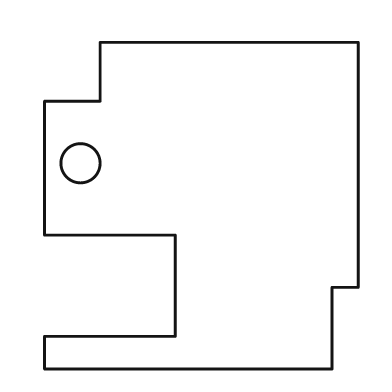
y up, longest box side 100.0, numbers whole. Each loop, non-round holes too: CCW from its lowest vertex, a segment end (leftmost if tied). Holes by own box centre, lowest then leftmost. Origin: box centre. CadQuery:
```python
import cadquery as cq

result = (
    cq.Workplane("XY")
    .moveTo(-48.0, -50.0)
    .lineTo(40.0, -50.0)
    .lineTo(40.0, -25.0)
    .lineTo(48.0, -25.0)
    .lineTo(48.0, 50.0)
    .lineTo(-31.0, 50.0)
    .lineTo(-31.0, 32.0)
    .lineTo(-48.0, 32.0)
    .lineTo(-48.0, -9.0)
    .lineTo(-8.0, -9.0)
    .lineTo(-8.0, -40.0)
    .lineTo(-48.0, -40.0)
    .close()
    .moveTo(-37.0, 13.0)
    .circle(6.0)
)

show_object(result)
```